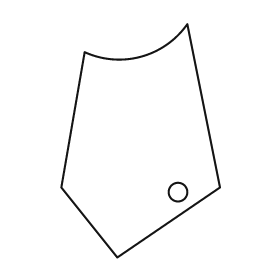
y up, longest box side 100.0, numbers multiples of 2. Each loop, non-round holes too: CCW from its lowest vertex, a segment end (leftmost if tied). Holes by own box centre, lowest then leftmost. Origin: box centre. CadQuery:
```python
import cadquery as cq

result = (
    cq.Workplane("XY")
    .moveTo(-10.0, -50.0)
    .lineTo(34.0, -20.0)
    .lineTo(20.0, 50.0)
    .threePointArc((0.0, 36.0), (-24.0, 38.0))
    .lineTo(-34.0, -20.0)
    .close()
    .moveTo(16.0, -22.0)
    .circle(4.0)
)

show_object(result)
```